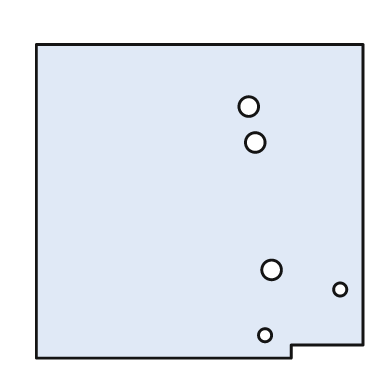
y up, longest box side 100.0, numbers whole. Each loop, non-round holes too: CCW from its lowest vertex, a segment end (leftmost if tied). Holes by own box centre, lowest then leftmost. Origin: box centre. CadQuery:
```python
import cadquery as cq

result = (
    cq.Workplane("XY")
    .moveTo(-50.0, -48.0)
    .lineTo(28.0, -48.0)
    .lineTo(28.0, -44.0)
    .lineTo(50.0, -44.0)
    .lineTo(50.0, 48.0)
    .lineTo(-50.0, 48.0)
    .close()
    .moveTo(20.0, -41.0)
    .circle(2.0)
    .moveTo(43.0, -27.0)
    .circle(2.0)
    .moveTo(22.0, -21.0)
    .circle(3.0)
    .moveTo(17.0, 18.0)
    .circle(3.0)
    .moveTo(15.0, 29.0)
    .circle(3.0)
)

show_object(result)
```